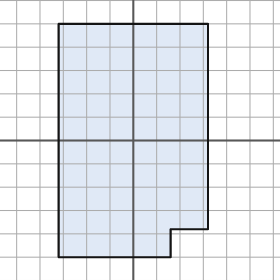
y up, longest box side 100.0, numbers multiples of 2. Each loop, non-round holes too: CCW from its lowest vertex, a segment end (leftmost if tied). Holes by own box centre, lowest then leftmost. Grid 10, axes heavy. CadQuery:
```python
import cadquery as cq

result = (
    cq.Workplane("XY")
    .moveTo(-32.0, -50.0)
    .lineTo(16.0, -50.0)
    .lineTo(16.0, -38.0)
    .lineTo(32.0, -38.0)
    .lineTo(32.0, 50.0)
    .lineTo(-32.0, 50.0)
    .close()
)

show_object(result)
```